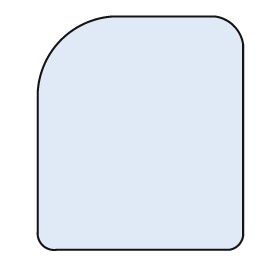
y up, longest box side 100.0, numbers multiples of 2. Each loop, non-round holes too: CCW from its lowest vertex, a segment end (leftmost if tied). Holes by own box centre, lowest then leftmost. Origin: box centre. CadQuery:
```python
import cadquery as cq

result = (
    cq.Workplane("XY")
    .moveTo(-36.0, -50.0)
    .lineTo(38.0, -50.0)
    .threePointArc((42.0, -48.0), (44.0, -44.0))
    .lineTo(44.0, 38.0)
    .threePointArc((40.0, 46.0), (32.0, 50.0))
    .lineTo(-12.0, 50.0)
    .threePointArc((-34.0, 40.0), (-44.0, 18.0))
    .lineTo(-44.0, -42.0)
    .threePointArc((-42.0, -48.0), (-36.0, -50.0))
    .close()
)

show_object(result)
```